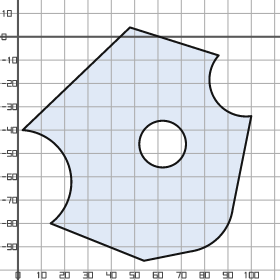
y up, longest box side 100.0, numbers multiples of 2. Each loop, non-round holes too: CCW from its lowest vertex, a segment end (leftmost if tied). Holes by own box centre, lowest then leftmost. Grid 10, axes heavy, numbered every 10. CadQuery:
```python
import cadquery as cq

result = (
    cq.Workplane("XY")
    .moveTo(54.0, -96.0)
    .lineTo(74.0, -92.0)
    .threePointArc((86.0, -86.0), (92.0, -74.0))
    .lineTo(100.0, -34.0)
    .threePointArc((84.0, -26.0), (86.0, -8.0))
    .lineTo(48.0, 4.0)
    .lineTo(2.0, -40.0)
    .threePointArc((22.0, -56.0), (14.0, -80.0))
    .close()
    .moveTo(62.0, -46.0)
    .circle(10.0)
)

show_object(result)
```